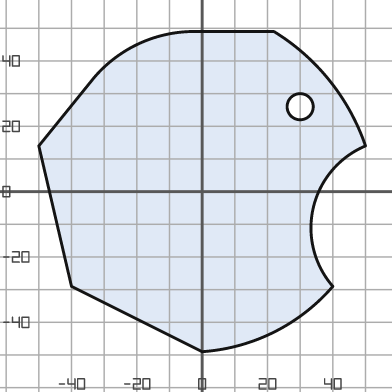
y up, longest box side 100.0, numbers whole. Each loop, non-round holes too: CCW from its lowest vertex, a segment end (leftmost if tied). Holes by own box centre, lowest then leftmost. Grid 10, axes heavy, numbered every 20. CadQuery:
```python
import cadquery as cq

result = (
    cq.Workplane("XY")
    .moveTo(0.0, -49.0)
    .threePointArc((22.0, -43.0), (40.0, -29.0))
    .threePointArc((34.0, -5.0), (50.0, 14.0))
    .threePointArc((39.0, 34.0), (22.0, 49.0))
    .lineTo(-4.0, 49.0)
    .threePointArc((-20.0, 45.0), (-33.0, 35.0))
    .lineTo(-50.0, 14.0)
    .lineTo(-40.0, -29.0)
    .close()
    .moveTo(30.0, 26.0)
    .circle(4.0)
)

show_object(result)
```